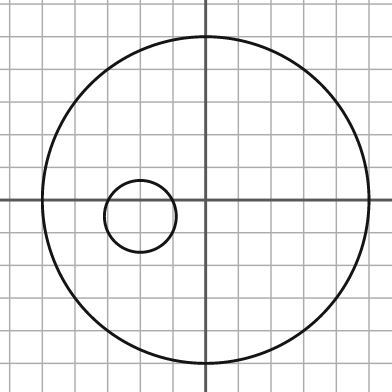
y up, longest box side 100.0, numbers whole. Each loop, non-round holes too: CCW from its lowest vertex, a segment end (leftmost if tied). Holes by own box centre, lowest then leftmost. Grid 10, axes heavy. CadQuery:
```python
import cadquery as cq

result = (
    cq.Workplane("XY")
    .moveTo(0.0, 0.0)
    .circle(50.0)
    .moveTo(-20.0, -5.0)
    .circle(11.0)
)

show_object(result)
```